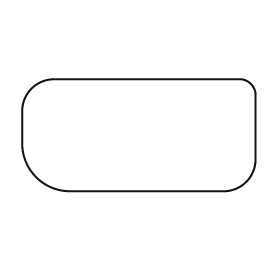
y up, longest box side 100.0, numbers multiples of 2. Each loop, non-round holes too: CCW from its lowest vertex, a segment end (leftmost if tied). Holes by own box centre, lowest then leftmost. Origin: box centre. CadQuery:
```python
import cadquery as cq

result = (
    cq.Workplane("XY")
    .moveTo(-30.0, -24.0)
    .lineTo(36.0, -24.0)
    .threePointArc((46.0, -20.0), (50.0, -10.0))
    .lineTo(50.0, 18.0)
    .threePointArc((48.0, 22.0), (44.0, 24.0))
    .lineTo(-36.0, 24.0)
    .threePointArc((-46.0, 20.0), (-50.0, 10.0))
    .lineTo(-50.0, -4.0)
    .threePointArc((-44.0, -18.0), (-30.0, -24.0))
    .close()
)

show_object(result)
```